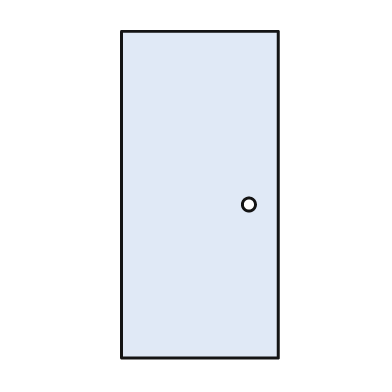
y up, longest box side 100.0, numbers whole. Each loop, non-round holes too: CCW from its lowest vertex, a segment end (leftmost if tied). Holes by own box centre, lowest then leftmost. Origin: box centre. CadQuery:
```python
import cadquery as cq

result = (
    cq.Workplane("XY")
    .moveTo(-24.0, -50.0)
    .lineTo(24.0, -50.0)
    .lineTo(24.0, 50.0)
    .lineTo(-24.0, 50.0)
    .close()
    .moveTo(15.0, -3.0)
    .circle(2.0)
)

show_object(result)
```